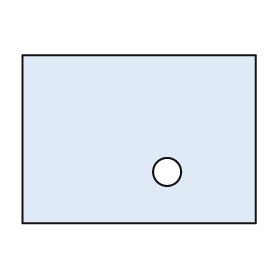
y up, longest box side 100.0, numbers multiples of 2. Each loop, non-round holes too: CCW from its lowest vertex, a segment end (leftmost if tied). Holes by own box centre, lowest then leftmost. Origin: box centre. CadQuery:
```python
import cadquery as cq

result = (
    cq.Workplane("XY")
    .moveTo(-50.0, -36.0)
    .lineTo(50.0, -36.0)
    .lineTo(50.0, 36.0)
    .lineTo(-50.0, 36.0)
    .close()
    .moveTo(12.0, -14.0)
    .circle(6.0)
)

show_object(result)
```